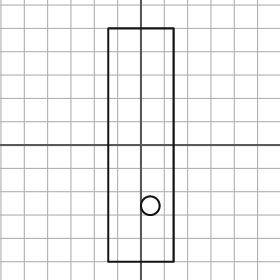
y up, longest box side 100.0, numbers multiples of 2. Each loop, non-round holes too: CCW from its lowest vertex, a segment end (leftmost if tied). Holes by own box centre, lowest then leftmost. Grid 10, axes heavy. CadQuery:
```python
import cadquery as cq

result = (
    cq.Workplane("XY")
    .moveTo(-14.0, -50.0)
    .lineTo(14.0, -50.0)
    .lineTo(14.0, 50.0)
    .lineTo(-14.0, 50.0)
    .close()
    .moveTo(4.0, -26.0)
    .circle(4.0)
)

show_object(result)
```